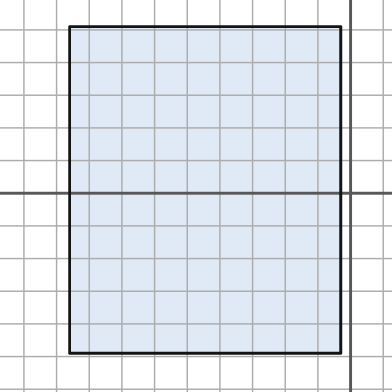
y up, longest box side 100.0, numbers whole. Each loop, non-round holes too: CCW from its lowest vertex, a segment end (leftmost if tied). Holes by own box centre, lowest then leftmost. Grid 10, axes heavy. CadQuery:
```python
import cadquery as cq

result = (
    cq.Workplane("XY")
    .moveTo(-86.0, -49.0)
    .lineTo(-3.0, -49.0)
    .lineTo(-3.0, 51.0)
    .lineTo(-86.0, 51.0)
    .close()
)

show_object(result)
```